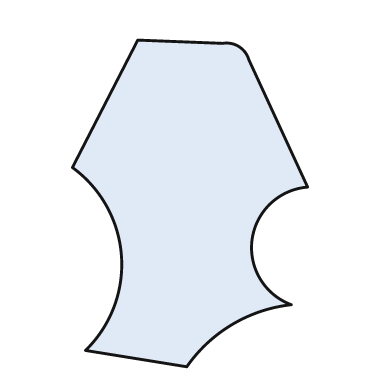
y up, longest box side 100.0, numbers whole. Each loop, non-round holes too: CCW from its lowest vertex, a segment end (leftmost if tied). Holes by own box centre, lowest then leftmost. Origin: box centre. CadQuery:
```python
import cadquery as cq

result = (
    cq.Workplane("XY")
    .moveTo(-1.0, -50.0)
    .threePointArc((13.0, -37.0), (31.0, -31.0))
    .threePointArc((19.0, -11.0), (36.0, 5.0))
    .lineTo(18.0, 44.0)
    .threePointArc((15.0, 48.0), (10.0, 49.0))
    .lineTo(-16.0, 50.0)
    .lineTo(-36.0, 11.0)
    .threePointArc((-21.0, -16.0), (-32.0, -45.0))
    .close()
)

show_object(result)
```